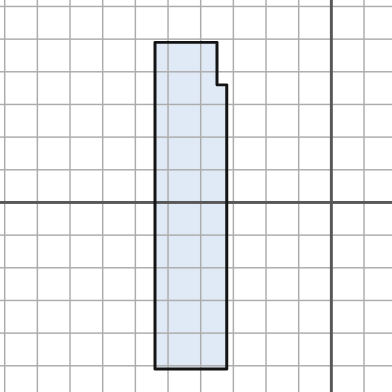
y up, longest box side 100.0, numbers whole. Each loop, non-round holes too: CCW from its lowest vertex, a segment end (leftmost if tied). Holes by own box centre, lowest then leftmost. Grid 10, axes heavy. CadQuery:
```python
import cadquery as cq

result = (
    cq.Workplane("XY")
    .moveTo(-54.0, -51.0)
    .lineTo(-32.0, -51.0)
    .lineTo(-32.0, 36.0)
    .lineTo(-35.0, 36.0)
    .lineTo(-35.0, 49.0)
    .lineTo(-54.0, 49.0)
    .close()
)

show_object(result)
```